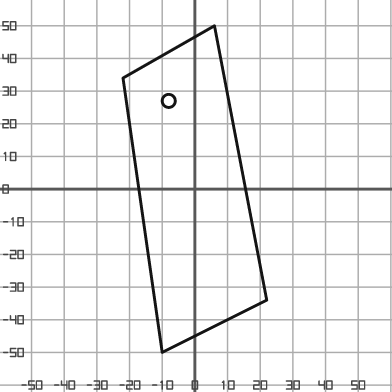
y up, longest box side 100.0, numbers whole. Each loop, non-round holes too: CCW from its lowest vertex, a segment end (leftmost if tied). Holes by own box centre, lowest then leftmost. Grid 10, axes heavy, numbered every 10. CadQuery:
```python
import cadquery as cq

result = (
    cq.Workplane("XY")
    .moveTo(-10.0, -50.0)
    .lineTo(22.0, -34.0)
    .lineTo(6.0, 50.0)
    .lineTo(-22.0, 34.0)
    .close()
    .moveTo(-8.0, 27.0)
    .circle(2.0)
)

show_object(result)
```